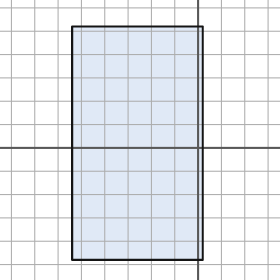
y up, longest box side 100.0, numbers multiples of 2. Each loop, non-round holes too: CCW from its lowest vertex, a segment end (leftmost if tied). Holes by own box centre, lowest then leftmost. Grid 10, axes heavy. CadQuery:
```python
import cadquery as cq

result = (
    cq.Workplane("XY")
    .moveTo(-54.0, -48.0)
    .lineTo(2.0, -48.0)
    .lineTo(2.0, 52.0)
    .lineTo(-54.0, 52.0)
    .close()
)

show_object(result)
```